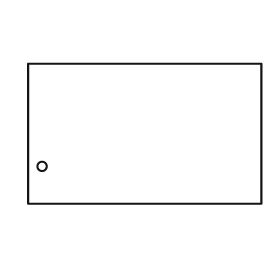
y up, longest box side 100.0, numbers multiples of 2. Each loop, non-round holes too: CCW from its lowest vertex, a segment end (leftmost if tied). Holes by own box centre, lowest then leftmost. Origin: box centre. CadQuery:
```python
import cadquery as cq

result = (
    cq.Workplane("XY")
    .moveTo(-50.0, -30.0)
    .lineTo(50.0, -30.0)
    .lineTo(50.0, 30.0)
    .lineTo(-50.0, 30.0)
    .close()
    .moveTo(-44.0, -14.0)
    .circle(2.0)
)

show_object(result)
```